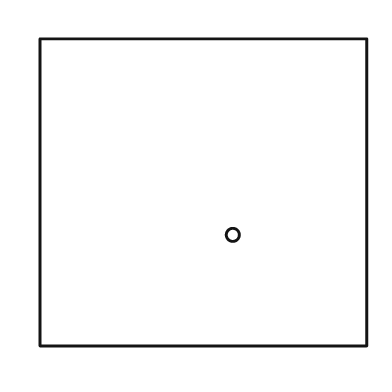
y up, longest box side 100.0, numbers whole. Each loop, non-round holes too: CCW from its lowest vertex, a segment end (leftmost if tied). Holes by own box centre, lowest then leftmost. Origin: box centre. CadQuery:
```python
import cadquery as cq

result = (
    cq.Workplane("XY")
    .moveTo(-50.0, -47.0)
    .lineTo(50.0, -47.0)
    .lineTo(50.0, 47.0)
    .lineTo(-50.0, 47.0)
    .close()
    .moveTo(9.0, -13.0)
    .circle(2.0)
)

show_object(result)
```